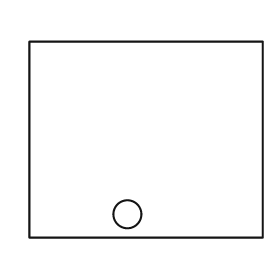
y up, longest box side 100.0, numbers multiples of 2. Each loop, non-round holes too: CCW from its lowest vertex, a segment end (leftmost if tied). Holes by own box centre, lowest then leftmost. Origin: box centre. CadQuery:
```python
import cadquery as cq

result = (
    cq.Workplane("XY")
    .moveTo(-50.0, -42.0)
    .lineTo(50.0, -42.0)
    .lineTo(50.0, 42.0)
    .lineTo(-50.0, 42.0)
    .close()
    .moveTo(-8.0, -32.0)
    .circle(6.0)
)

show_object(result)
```